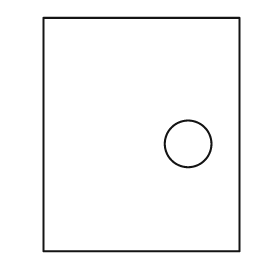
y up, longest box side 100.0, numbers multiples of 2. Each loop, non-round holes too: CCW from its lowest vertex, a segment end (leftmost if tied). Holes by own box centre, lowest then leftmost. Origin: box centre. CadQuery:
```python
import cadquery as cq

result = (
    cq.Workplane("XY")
    .moveTo(-42.0, -50.0)
    .lineTo(42.0, -50.0)
    .lineTo(42.0, 50.0)
    .lineTo(-42.0, 50.0)
    .close()
    .moveTo(20.0, -4.0)
    .circle(10.0)
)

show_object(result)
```